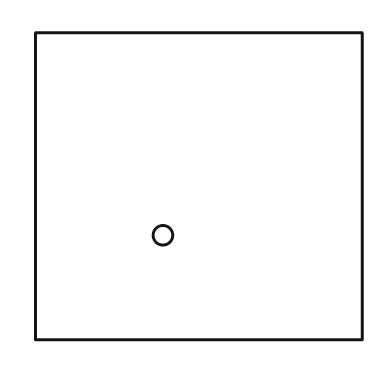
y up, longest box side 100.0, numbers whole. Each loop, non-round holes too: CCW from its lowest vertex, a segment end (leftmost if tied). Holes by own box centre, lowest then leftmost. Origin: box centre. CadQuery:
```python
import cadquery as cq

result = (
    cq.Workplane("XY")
    .moveTo(-50.0, -47.0)
    .lineTo(50.0, -47.0)
    .lineTo(50.0, 47.0)
    .lineTo(-50.0, 47.0)
    .close()
    .moveTo(-11.0, -15.0)
    .circle(3.0)
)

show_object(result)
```